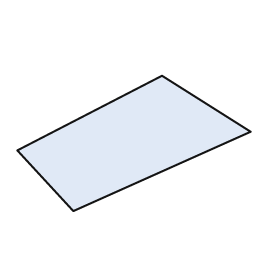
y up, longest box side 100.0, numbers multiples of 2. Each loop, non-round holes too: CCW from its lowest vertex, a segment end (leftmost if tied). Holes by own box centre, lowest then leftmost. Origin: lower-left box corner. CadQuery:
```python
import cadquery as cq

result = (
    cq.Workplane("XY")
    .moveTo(24.0, 0.0)
    .lineTo(100.0, 34.0)
    .lineTo(62.0, 58.0)
    .lineTo(0.0, 26.0)
    .close()
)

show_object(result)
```